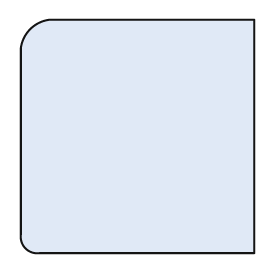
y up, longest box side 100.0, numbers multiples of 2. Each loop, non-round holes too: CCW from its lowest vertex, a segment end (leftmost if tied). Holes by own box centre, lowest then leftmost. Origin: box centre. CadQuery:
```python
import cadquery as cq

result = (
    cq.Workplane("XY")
    .moveTo(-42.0, -50.0)
    .lineTo(50.0, -50.0)
    .lineTo(50.0, 50.0)
    .lineTo(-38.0, 50.0)
    .threePointArc((-46.0, 46.0), (-50.0, 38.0))
    .lineTo(-50.0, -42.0)
    .threePointArc((-48.0, -48.0), (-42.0, -50.0))
    .close()
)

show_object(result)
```